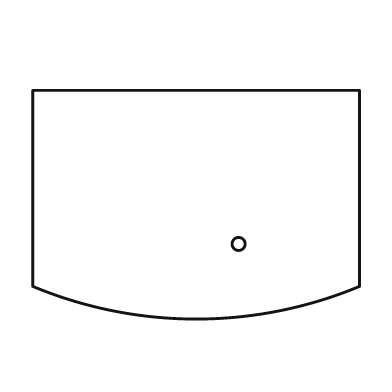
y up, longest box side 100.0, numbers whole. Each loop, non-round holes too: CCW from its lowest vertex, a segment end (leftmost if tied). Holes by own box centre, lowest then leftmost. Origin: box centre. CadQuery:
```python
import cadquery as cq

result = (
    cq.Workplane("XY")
    .moveTo(-50.0, -25.0)
    .threePointArc((0.0, -35.0), (50.0, -25.0))
    .lineTo(50.0, 35.0)
    .lineTo(-50.0, 35.0)
    .close()
    .moveTo(13.0, -12.0)
    .circle(2.0)
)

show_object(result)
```